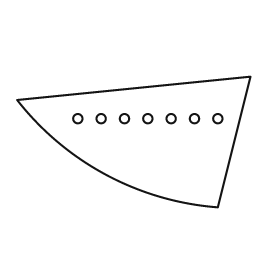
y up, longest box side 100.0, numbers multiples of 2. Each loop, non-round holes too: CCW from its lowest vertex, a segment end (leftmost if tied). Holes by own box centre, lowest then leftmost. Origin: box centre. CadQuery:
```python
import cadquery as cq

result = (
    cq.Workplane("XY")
    .moveTo(36.0, -28.0)
    .lineTo(50.0, 28.0)
    .lineTo(-50.0, 18.0)
    .threePointArc((-12.0, -14.0), (36.0, -28.0))
    .close()
    .moveTo(-24.0, 10.0)
    .circle(2.0)
    .moveTo(-14.0, 10.0)
    .circle(2.0)
    .moveTo(-4.0, 10.0)
    .circle(2.0)
    .moveTo(6.0, 10.0)
    .circle(2.0)
    .moveTo(16.0, 10.0)
    .circle(2.0)
    .moveTo(26.0, 10.0)
    .circle(2.0)
    .moveTo(36.0, 10.0)
    .circle(2.0)
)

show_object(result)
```